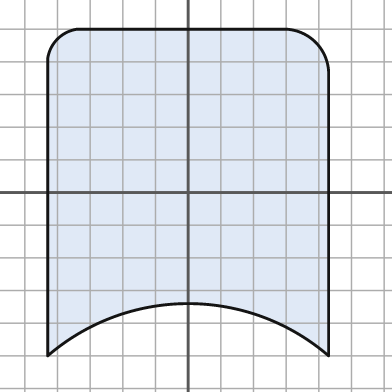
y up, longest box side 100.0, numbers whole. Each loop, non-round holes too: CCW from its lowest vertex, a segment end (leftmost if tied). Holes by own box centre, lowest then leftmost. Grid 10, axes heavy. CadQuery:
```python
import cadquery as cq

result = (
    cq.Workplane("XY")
    .moveTo(-43.0, -50.0)
    .threePointArc((0.0, -34.0), (43.0, -50.0))
    .lineTo(43.0, 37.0)
    .threePointArc((39.0, 46.0), (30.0, 50.0))
    .lineTo(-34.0, 50.0)
    .threePointArc((-40.0, 47.0), (-43.0, 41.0))
    .close()
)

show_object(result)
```